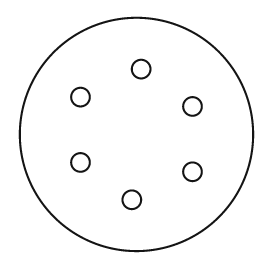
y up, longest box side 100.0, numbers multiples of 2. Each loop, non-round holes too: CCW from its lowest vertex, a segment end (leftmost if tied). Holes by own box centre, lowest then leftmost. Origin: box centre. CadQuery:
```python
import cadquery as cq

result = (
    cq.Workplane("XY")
    .moveTo(0.0, 0.0)
    .circle(50.0)
    .moveTo(-2.0, -28.0)
    .circle(4.0)
    .moveTo(24.0, -16.0)
    .circle(4.0)
    .moveTo(-24.0, -12.0)
    .circle(4.0)
    .moveTo(24.0, 12.0)
    .circle(4.0)
    .moveTo(-24.0, 16.0)
    .circle(4.0)
    .moveTo(2.0, 28.0)
    .circle(4.0)
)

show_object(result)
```